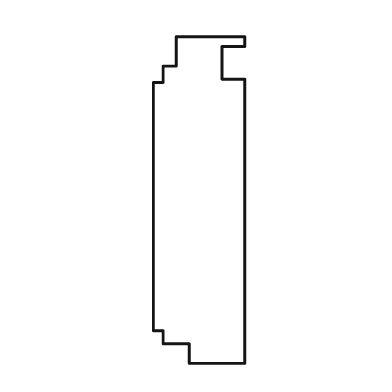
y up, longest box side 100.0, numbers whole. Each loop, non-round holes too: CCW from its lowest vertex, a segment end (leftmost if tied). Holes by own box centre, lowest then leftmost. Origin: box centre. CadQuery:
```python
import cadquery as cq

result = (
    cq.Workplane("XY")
    .moveTo(-3.0, -50.0)
    .lineTo(14.0, -50.0)
    .lineTo(14.0, 37.0)
    .lineTo(7.0, 37.0)
    .lineTo(7.0, 47.0)
    .lineTo(14.0, 47.0)
    .lineTo(14.0, 50.0)
    .lineTo(-7.0, 50.0)
    .lineTo(-7.0, 41.0)
    .lineTo(-11.0, 41.0)
    .lineTo(-11.0, 36.0)
    .lineTo(-14.0, 36.0)
    .lineTo(-14.0, -40.0)
    .lineTo(-11.0, -40.0)
    .lineTo(-11.0, -44.0)
    .lineTo(-3.0, -44.0)
    .close()
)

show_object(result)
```